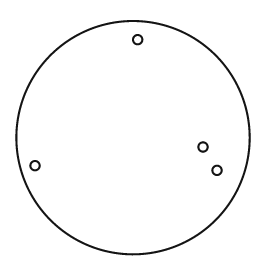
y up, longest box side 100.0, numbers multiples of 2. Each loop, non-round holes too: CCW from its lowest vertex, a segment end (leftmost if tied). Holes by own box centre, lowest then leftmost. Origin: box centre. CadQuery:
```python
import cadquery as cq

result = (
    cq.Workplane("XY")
    .moveTo(0.0, 0.0)
    .circle(50.0)
    .moveTo(36.0, -14.0)
    .circle(2.0)
    .moveTo(-42.0, -12.0)
    .circle(2.0)
    .moveTo(30.0, -4.0)
    .circle(2.0)
    .moveTo(2.0, 42.0)
    .circle(2.0)
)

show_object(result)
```